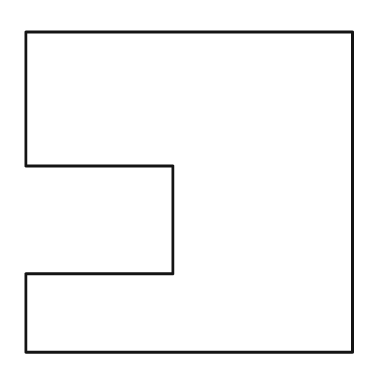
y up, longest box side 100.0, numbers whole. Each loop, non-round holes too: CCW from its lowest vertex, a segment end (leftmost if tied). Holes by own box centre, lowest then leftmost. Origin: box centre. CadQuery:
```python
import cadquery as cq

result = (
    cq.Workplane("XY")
    .moveTo(-50.0, -49.0)
    .lineTo(50.0, -49.0)
    .lineTo(50.0, 49.0)
    .lineTo(-50.0, 49.0)
    .lineTo(-50.0, 8.0)
    .lineTo(-5.0, 8.0)
    .lineTo(-5.0, -25.0)
    .lineTo(-50.0, -25.0)
    .close()
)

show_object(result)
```